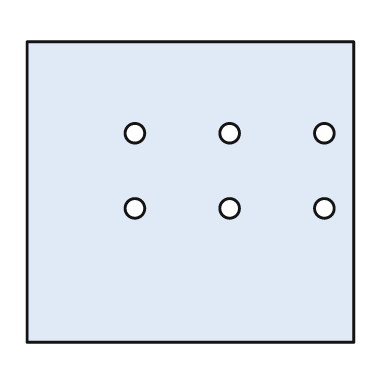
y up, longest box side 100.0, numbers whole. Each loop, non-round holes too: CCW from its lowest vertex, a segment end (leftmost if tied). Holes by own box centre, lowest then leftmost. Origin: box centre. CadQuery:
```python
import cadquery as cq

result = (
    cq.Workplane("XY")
    .moveTo(-50.0, -46.0)
    .lineTo(50.0, -46.0)
    .lineTo(50.0, 46.0)
    .lineTo(-50.0, 46.0)
    .close()
    .moveTo(-17.0, -5.0)
    .circle(3.0)
    .moveTo(12.0, -5.0)
    .circle(3.0)
    .moveTo(41.0, -5.0)
    .circle(3.0)
    .moveTo(-17.0, 18.0)
    .circle(3.0)
    .moveTo(12.0, 18.0)
    .circle(3.0)
    .moveTo(41.0, 18.0)
    .circle(3.0)
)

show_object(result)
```